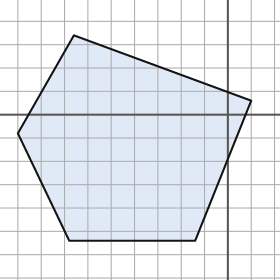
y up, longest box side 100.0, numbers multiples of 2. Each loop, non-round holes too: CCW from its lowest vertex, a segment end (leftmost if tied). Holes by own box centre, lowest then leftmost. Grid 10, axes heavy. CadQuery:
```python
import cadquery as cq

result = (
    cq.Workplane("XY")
    .moveTo(-68.0, -54.0)
    .lineTo(-14.0, -54.0)
    .lineTo(10.0, 6.0)
    .lineTo(-66.0, 34.0)
    .lineTo(-90.0, -8.0)
    .close()
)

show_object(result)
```